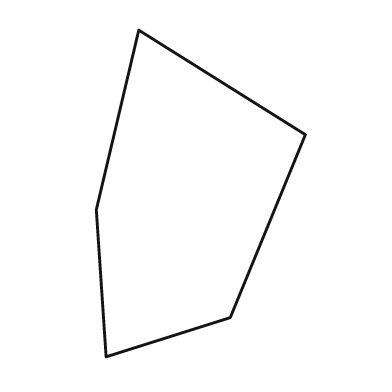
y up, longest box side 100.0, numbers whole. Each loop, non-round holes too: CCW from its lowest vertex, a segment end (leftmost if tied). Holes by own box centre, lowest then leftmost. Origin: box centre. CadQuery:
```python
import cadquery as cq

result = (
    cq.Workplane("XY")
    .moveTo(-29.0, -50.0)
    .lineTo(9.0, -38.0)
    .lineTo(32.0, 18.0)
    .lineTo(-19.0, 50.0)
    .lineTo(-32.0, -5.0)
    .close()
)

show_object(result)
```